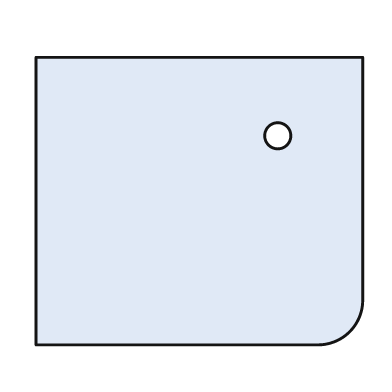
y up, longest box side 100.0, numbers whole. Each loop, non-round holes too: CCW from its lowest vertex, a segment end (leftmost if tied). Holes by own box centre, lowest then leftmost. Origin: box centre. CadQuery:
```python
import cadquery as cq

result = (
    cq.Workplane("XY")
    .moveTo(-50.0, -44.0)
    .lineTo(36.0, -44.0)
    .threePointArc((46.0, -40.0), (50.0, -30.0))
    .lineTo(50.0, 44.0)
    .lineTo(-50.0, 44.0)
    .close()
    .moveTo(24.0, 20.0)
    .circle(4.0)
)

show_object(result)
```